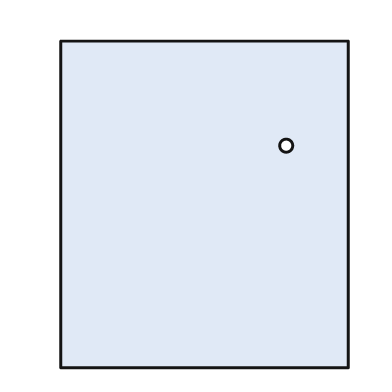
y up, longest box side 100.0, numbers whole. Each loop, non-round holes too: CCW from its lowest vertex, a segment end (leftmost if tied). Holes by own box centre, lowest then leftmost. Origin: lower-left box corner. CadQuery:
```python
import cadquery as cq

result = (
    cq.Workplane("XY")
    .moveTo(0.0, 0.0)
    .lineTo(88.0, 0.0)
    .lineTo(88.0, 100.0)
    .lineTo(0.0, 100.0)
    .close()
    .moveTo(69.0, 68.0)
    .circle(2.0)
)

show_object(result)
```